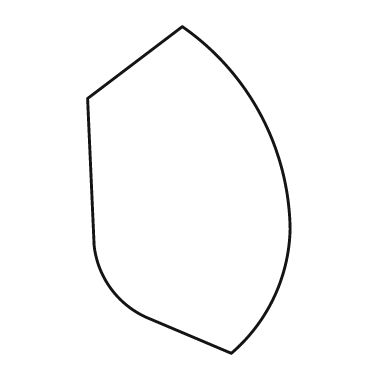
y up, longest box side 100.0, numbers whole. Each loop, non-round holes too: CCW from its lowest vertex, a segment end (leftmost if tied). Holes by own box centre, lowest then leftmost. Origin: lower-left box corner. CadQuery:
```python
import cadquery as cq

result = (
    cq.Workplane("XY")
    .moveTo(44.0, 0.0)
    .threePointArc((57.0, 17.0), (62.0, 38.0))
    .threePointArc((53.0, 73.0), (29.0, 100.0))
    .lineTo(0.0, 78.0)
    .lineTo(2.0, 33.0)
    .threePointArc((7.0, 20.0), (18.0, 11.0))
    .close()
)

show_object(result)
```